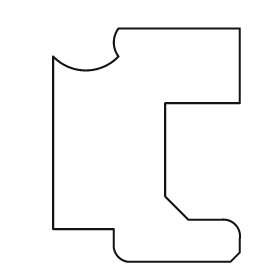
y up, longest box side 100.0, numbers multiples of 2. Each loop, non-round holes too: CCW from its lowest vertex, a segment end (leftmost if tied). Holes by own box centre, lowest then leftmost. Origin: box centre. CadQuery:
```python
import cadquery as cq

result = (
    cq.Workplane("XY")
    .moveTo(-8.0, -50.0)
    .lineTo(36.0, -50.0)
    .lineTo(40.0, -46.0)
    .lineTo(40.0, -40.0)
    .threePointArc((38.0, -34.0), (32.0, -32.0))
    .lineTo(18.0, -32.0)
    .lineTo(8.0, -22.0)
    .lineTo(8.0, 18.0)
    .lineTo(40.0, 18.0)
    .lineTo(40.0, 50.0)
    .lineTo(-12.0, 50.0)
    .threePointArc((-14.0, 44.0), (-12.0, 38.0))
    .threePointArc((-26.0, 32.0), (-40.0, 38.0))
    .lineTo(-40.0, -36.0)
    .lineTo(-14.0, -36.0)
    .lineTo(-14.0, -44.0)
    .threePointArc((-12.0, -48.0), (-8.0, -50.0))
    .close()
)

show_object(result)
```